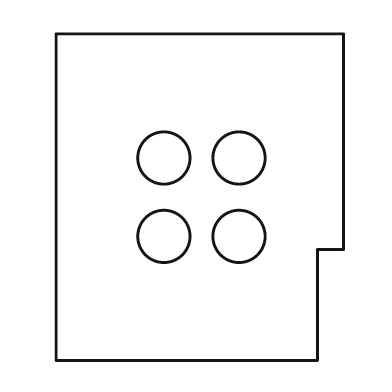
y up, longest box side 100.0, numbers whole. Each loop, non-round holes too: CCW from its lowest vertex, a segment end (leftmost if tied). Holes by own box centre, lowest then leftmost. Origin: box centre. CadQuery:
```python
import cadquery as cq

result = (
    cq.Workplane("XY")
    .moveTo(-44.0, -50.0)
    .lineTo(36.0, -50.0)
    .lineTo(36.0, -16.0)
    .lineTo(44.0, -16.0)
    .lineTo(44.0, 50.0)
    .lineTo(-44.0, 50.0)
    .close()
    .moveTo(-11.0, -12.0)
    .circle(8.0)
    .moveTo(12.0, -12.0)
    .circle(8.0)
    .moveTo(-11.0, 12.0)
    .circle(8.0)
    .moveTo(12.0, 12.0)
    .circle(8.0)
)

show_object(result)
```